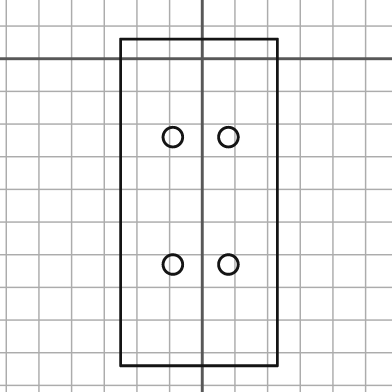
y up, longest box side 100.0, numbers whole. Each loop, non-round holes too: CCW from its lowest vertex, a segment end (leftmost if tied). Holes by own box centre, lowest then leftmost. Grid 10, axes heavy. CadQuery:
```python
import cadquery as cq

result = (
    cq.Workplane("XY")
    .moveTo(-25.0, -94.0)
    .lineTo(23.0, -94.0)
    .lineTo(23.0, 6.0)
    .lineTo(-25.0, 6.0)
    .close()
    .moveTo(-9.0, -63.0)
    .circle(3.0)
    .moveTo(8.0, -63.0)
    .circle(3.0)
    .moveTo(-9.0, -24.0)
    .circle(3.0)
    .moveTo(8.0, -24.0)
    .circle(3.0)
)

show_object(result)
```